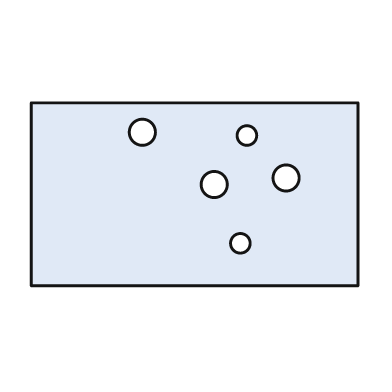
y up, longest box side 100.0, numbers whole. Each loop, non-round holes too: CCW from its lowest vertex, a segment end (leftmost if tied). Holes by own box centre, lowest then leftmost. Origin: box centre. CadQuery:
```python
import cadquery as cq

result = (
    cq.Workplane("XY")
    .moveTo(-50.0, -28.0)
    .lineTo(50.0, -28.0)
    .lineTo(50.0, 28.0)
    .lineTo(-50.0, 28.0)
    .close()
    .moveTo(14.0, -15.0)
    .circle(3.0)
    .moveTo(6.0, 3.0)
    .circle(4.0)
    .moveTo(28.0, 5.0)
    .circle(4.0)
    .moveTo(16.0, 18.0)
    .circle(3.0)
    .moveTo(-16.0, 19.0)
    .circle(4.0)
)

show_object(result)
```